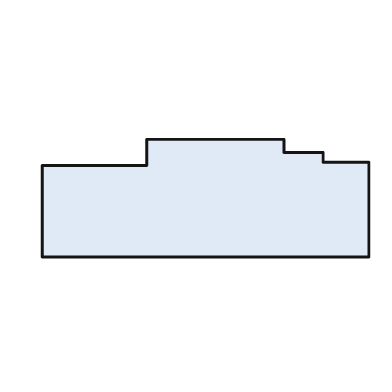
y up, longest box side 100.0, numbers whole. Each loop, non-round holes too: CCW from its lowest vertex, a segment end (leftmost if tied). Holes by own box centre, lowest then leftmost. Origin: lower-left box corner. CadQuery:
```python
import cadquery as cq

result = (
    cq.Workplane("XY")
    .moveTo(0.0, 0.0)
    .lineTo(100.0, 0.0)
    .lineTo(100.0, 29.0)
    .lineTo(86.0, 29.0)
    .lineTo(86.0, 32.0)
    .lineTo(74.0, 32.0)
    .lineTo(74.0, 36.0)
    .lineTo(32.0, 36.0)
    .lineTo(32.0, 28.0)
    .lineTo(0.0, 28.0)
    .close()
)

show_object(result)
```